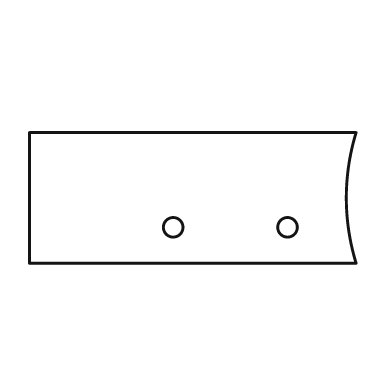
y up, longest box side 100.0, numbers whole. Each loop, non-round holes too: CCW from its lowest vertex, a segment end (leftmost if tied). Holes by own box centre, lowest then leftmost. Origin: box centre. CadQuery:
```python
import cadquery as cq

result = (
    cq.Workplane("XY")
    .moveTo(-50.0, -20.0)
    .lineTo(50.0, -20.0)
    .threePointArc((47.0, 0.0), (50.0, 20.0))
    .lineTo(-50.0, 20.0)
    .close()
    .moveTo(-6.0, -9.0)
    .circle(3.0)
    .moveTo(29.0, -9.0)
    .circle(3.0)
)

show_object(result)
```